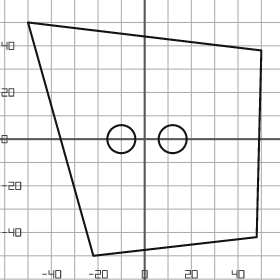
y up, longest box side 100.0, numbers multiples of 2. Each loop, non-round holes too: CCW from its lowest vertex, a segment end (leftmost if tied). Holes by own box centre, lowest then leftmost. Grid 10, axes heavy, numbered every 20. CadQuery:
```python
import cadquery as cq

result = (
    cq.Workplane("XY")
    .moveTo(-22.0, -50.0)
    .lineTo(48.0, -42.0)
    .lineTo(50.0, 38.0)
    .lineTo(-50.0, 50.0)
    .close()
    .moveTo(-10.0, 0.0)
    .circle(6.0)
    .moveTo(12.0, 0.0)
    .circle(6.0)
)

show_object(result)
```